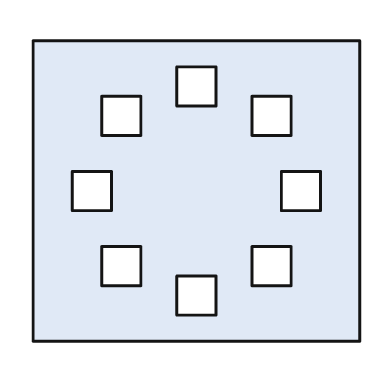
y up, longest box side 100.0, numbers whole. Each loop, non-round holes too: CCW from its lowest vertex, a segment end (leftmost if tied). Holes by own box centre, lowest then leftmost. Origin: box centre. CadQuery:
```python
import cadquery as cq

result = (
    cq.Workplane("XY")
    .moveTo(-50.0, -46.0)
    .lineTo(50.0, -46.0)
    .lineTo(50.0, 46.0)
    .lineTo(-50.0, 46.0)
    .close()
    .moveTo(-6.0, -38.0)
    .lineTo(6.0, -38.0)
    .lineTo(6.0, -26.0)
    .lineTo(-6.0, -26.0)
    .close()
    .moveTo(-29.0, -29.0)
    .lineTo(-17.0, -29.0)
    .lineTo(-17.0, -17.0)
    .lineTo(-29.0, -17.0)
    .close()
    .moveTo(17.0, -29.0)
    .lineTo(29.0, -29.0)
    .lineTo(29.0, -17.0)
    .lineTo(17.0, -17.0)
    .close()
    .moveTo(-38.0, -6.0)
    .lineTo(-26.0, -6.0)
    .lineTo(-26.0, 6.0)
    .lineTo(-38.0, 6.0)
    .close()
    .moveTo(26.0, -6.0)
    .lineTo(38.0, -6.0)
    .lineTo(38.0, 6.0)
    .lineTo(26.0, 6.0)
    .close()
    .moveTo(-29.0, 17.0)
    .lineTo(-17.0, 17.0)
    .lineTo(-17.0, 29.0)
    .lineTo(-29.0, 29.0)
    .close()
    .moveTo(17.0, 17.0)
    .lineTo(29.0, 17.0)
    .lineTo(29.0, 29.0)
    .lineTo(17.0, 29.0)
    .close()
    .moveTo(-6.0, 26.0)
    .lineTo(6.0, 26.0)
    .lineTo(6.0, 38.0)
    .lineTo(-6.0, 38.0)
    .close()
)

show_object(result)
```